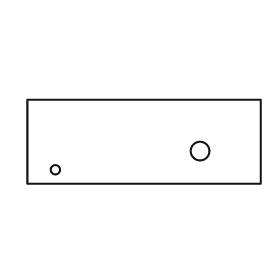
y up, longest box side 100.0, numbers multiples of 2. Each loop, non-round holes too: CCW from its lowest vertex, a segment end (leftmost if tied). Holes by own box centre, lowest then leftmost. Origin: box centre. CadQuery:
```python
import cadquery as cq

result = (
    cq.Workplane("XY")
    .moveTo(-50.0, -18.0)
    .lineTo(50.0, -18.0)
    .lineTo(50.0, 18.0)
    .lineTo(-50.0, 18.0)
    .close()
    .moveTo(-38.0, -12.0)
    .circle(2.0)
    .moveTo(24.0, -4.0)
    .circle(4.0)
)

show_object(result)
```